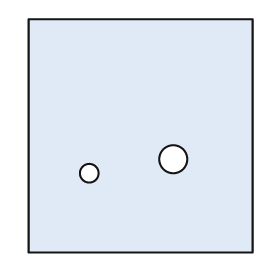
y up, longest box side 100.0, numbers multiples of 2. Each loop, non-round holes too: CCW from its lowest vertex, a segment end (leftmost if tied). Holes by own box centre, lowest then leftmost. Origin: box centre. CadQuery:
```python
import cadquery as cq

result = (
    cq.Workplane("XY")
    .moveTo(-48.0, -50.0)
    .lineTo(48.0, -50.0)
    .lineTo(48.0, 50.0)
    .lineTo(-48.0, 50.0)
    .close()
    .moveTo(-22.0, -16.0)
    .circle(4.0)
    .moveTo(14.0, -10.0)
    .circle(6.0)
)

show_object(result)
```